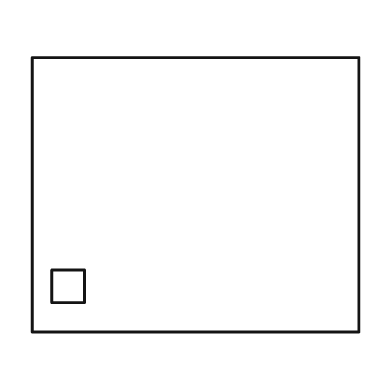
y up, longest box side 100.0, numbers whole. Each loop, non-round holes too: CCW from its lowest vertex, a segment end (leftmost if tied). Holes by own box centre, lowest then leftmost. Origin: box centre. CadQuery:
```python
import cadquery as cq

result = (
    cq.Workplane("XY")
    .moveTo(-50.0, -42.0)
    .lineTo(50.0, -42.0)
    .lineTo(50.0, 42.0)
    .lineTo(-50.0, 42.0)
    .close()
    .moveTo(-44.0, -33.0)
    .lineTo(-34.0, -33.0)
    .lineTo(-34.0, -23.0)
    .lineTo(-44.0, -23.0)
    .close()
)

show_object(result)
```